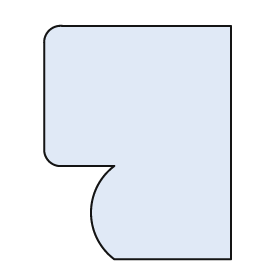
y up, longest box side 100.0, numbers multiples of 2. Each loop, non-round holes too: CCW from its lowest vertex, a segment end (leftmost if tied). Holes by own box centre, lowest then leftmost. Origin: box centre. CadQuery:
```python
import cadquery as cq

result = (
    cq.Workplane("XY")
    .moveTo(-10.0, -50.0)
    .lineTo(40.0, -50.0)
    .lineTo(40.0, 50.0)
    .lineTo(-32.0, 50.0)
    .threePointArc((-38.0, 48.0), (-40.0, 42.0))
    .lineTo(-40.0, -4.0)
    .threePointArc((-38.0, -8.0), (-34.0, -10.0))
    .lineTo(-10.0, -10.0)
    .threePointArc((-20.0, -30.0), (-10.0, -50.0))
    .close()
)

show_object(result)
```